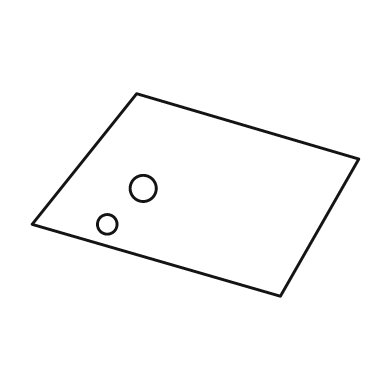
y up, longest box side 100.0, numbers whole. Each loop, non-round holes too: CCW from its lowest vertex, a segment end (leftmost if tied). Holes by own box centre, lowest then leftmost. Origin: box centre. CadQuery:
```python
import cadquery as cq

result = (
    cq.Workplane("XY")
    .moveTo(26.0, -31.0)
    .lineTo(50.0, 11.0)
    .lineTo(-18.0, 31.0)
    .lineTo(-50.0, -9.0)
    .close()
    .moveTo(-27.0, -9.0)
    .circle(3.0)
    .moveTo(-16.0, 2.0)
    .circle(4.0)
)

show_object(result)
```